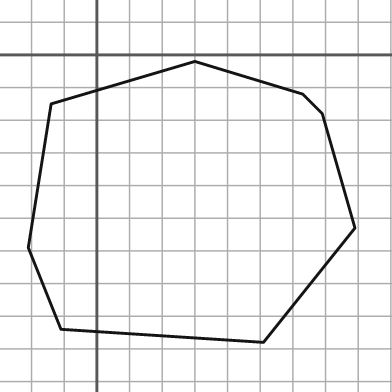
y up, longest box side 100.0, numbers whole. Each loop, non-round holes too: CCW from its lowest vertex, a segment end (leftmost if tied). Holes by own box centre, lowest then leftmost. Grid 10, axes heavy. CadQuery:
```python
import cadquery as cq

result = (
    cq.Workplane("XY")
    .moveTo(51.0, -88.0)
    .lineTo(79.0, -53.0)
    .lineTo(69.0, -18.0)
    .lineTo(63.0, -12.0)
    .lineTo(30.0, -2.0)
    .lineTo(-14.0, -15.0)
    .lineTo(-21.0, -59.0)
    .lineTo(-11.0, -84.0)
    .close()
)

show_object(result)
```